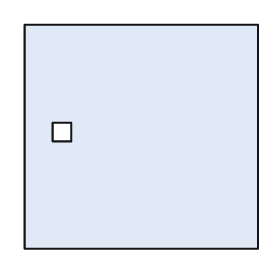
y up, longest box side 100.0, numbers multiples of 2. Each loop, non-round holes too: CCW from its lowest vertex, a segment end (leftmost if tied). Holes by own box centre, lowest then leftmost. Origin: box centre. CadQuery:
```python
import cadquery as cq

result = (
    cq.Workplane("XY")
    .moveTo(-50.0, -48.0)
    .lineTo(50.0, -48.0)
    .lineTo(50.0, 48.0)
    .lineTo(-50.0, 48.0)
    .close()
    .moveTo(-38.0, -2.0)
    .lineTo(-30.0, -2.0)
    .lineTo(-30.0, 6.0)
    .lineTo(-38.0, 6.0)
    .close()
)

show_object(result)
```